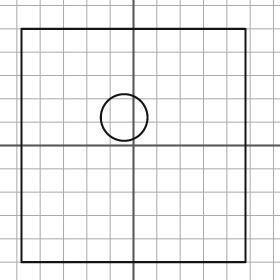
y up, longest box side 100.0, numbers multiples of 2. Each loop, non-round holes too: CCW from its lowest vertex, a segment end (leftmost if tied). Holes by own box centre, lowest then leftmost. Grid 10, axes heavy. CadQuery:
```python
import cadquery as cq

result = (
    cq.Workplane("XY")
    .moveTo(-48.0, -50.0)
    .lineTo(48.0, -50.0)
    .lineTo(48.0, 50.0)
    .lineTo(-48.0, 50.0)
    .close()
    .moveTo(-4.0, 12.0)
    .circle(10.0)
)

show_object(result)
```